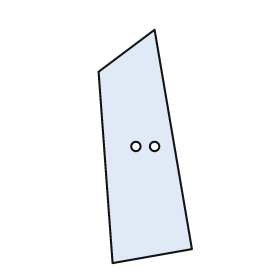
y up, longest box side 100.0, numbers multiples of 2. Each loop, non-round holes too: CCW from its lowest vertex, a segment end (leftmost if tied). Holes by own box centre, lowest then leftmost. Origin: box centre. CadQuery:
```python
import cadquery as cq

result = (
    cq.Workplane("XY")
    .moveTo(-14.0, -50.0)
    .lineTo(20.0, -44.0)
    .lineTo(4.0, 50.0)
    .lineTo(-20.0, 32.0)
    .close()
    .moveTo(-4.0, 0.0)
    .circle(2.0)
    .moveTo(4.0, 0.0)
    .circle(2.0)
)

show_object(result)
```